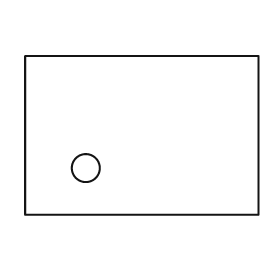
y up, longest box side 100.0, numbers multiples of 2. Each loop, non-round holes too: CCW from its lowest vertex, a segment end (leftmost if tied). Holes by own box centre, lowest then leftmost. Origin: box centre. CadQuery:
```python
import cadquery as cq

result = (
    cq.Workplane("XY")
    .moveTo(-50.0, -34.0)
    .lineTo(50.0, -34.0)
    .lineTo(50.0, 34.0)
    .lineTo(-50.0, 34.0)
    .close()
    .moveTo(-24.0, -14.0)
    .circle(6.0)
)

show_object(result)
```